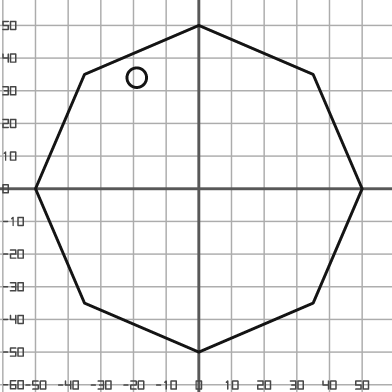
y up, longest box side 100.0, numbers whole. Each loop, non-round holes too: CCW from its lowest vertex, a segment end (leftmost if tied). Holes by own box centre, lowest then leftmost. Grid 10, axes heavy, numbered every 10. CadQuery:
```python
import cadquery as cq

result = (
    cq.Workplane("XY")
    .moveTo(0.0, -50.0)
    .lineTo(35.0, -35.0)
    .lineTo(50.0, 0.0)
    .lineTo(35.0, 35.0)
    .lineTo(0.0, 50.0)
    .lineTo(-35.0, 35.0)
    .lineTo(-50.0, 0.0)
    .lineTo(-35.0, -35.0)
    .close()
    .moveTo(-19.0, 34.0)
    .circle(3.0)
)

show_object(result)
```